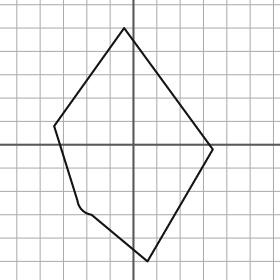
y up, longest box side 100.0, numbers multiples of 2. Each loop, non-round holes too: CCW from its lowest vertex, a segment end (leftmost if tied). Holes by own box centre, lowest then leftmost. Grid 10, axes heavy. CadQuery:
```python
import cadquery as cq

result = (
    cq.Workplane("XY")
    .moveTo(6.0, -50.0)
    .lineTo(34.0, -2.0)
    .lineTo(-4.0, 50.0)
    .lineTo(-34.0, 8.0)
    .lineTo(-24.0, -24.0)
    .threePointArc((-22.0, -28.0), (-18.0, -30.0))
    .close()
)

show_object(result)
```